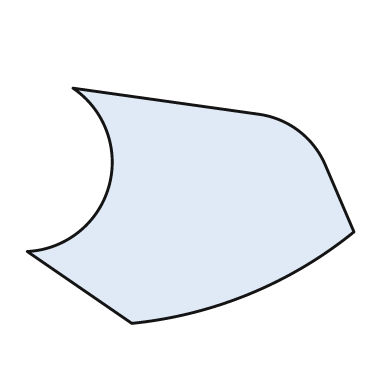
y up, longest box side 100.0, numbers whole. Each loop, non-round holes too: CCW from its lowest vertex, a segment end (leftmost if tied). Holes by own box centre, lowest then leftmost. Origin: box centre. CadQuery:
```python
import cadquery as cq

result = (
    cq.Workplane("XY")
    .moveTo(-18.0, -36.0)
    .threePointArc((18.0, -27.0), (50.0, -8.0))
    .lineTo(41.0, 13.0)
    .threePointArc((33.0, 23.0), (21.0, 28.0))
    .lineTo(-36.0, 36.0)
    .threePointArc((-25.0, 6.0), (-50.0, -14.0))
    .close()
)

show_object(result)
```